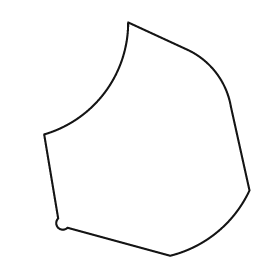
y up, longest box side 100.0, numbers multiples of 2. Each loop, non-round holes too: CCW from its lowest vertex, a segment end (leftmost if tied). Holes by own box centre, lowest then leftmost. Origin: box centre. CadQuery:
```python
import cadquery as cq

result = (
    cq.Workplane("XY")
    .moveTo(10.0, -50.0)
    .threePointArc((30.0, -40.0), (44.0, -22.0))
    .lineTo(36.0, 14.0)
    .threePointArc((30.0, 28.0), (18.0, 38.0))
    .lineTo(-8.0, 50.0)
    .threePointArc((-18.0, 20.0), (-44.0, 2.0))
    .lineTo(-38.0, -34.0)
    .threePointArc((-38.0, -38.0), (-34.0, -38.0))
    .close()
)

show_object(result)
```